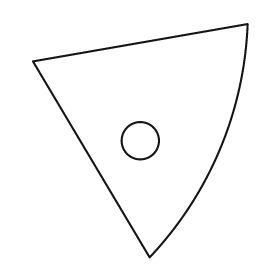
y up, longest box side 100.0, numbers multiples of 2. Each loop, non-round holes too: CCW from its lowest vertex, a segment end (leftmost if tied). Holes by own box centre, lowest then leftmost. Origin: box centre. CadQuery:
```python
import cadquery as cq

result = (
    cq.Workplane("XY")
    .moveTo(4.0, -50.0)
    .threePointArc((34.0, -4.0), (46.0, 50.0))
    .lineTo(-46.0, 34.0)
    .close()
    .moveTo(0.0, 0.0)
    .circle(8.0)
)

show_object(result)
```